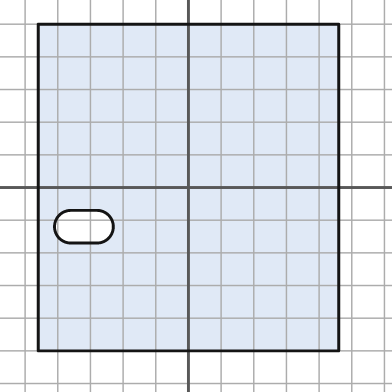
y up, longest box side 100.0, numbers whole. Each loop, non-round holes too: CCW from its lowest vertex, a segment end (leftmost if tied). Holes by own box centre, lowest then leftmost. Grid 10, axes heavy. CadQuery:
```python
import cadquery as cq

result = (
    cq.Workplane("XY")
    .moveTo(-46.0, -50.0)
    .lineTo(46.0, -50.0)
    .lineTo(46.0, 50.0)
    .lineTo(-46.0, 50.0)
    .close()
    .moveTo(-36.0, -17.0)
    .lineTo(-28.0, -17.0)
    .threePointArc((-23.0, -12.0), (-28.0, -7.0))
    .lineTo(-36.0, -7.0)
    .threePointArc((-41.0, -12.0), (-36.0, -17.0))
    .close()
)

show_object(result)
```